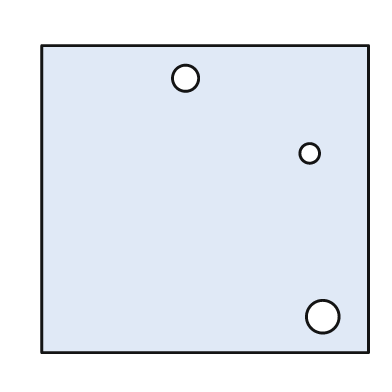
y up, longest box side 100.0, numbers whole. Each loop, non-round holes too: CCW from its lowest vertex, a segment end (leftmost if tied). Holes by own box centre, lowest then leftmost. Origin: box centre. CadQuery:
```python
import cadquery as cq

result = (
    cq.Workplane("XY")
    .moveTo(-50.0, -47.0)
    .lineTo(50.0, -47.0)
    .lineTo(50.0, 47.0)
    .lineTo(-50.0, 47.0)
    .close()
    .moveTo(36.0, -36.0)
    .circle(5.0)
    .moveTo(32.0, 14.0)
    .circle(3.0)
    .moveTo(-6.0, 37.0)
    .circle(4.0)
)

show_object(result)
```